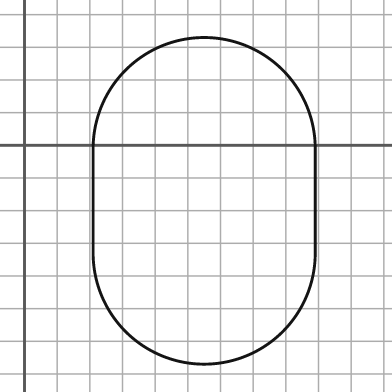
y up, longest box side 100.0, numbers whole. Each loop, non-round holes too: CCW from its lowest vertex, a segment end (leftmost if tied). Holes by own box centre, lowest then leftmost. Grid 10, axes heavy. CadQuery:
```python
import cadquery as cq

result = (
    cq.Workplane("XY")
    .moveTo(21.0, -33.0)
    .threePointArc((55.0, -67.0), (89.0, -33.0))
    .lineTo(89.0, -1.0)
    .threePointArc((55.0, 33.0), (21.0, -1.0))
    .close()
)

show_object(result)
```